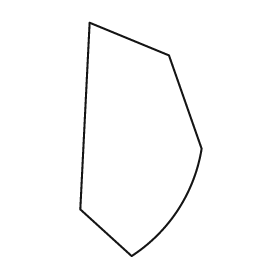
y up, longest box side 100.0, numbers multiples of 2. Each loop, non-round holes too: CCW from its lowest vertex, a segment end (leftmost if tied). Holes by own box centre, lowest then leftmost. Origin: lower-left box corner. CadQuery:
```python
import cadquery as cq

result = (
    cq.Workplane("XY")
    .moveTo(22.0, 0.0)
    .threePointArc((42.0, 20.0), (52.0, 46.0))
    .lineTo(38.0, 86.0)
    .lineTo(4.0, 100.0)
    .lineTo(0.0, 20.0)
    .close()
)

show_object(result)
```